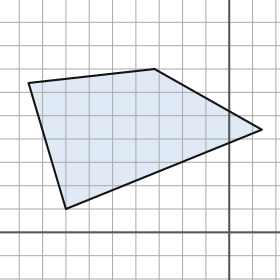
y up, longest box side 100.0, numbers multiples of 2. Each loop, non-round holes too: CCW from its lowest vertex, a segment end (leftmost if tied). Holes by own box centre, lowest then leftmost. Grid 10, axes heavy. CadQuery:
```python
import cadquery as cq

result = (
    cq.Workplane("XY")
    .moveTo(-70.0, 10.0)
    .lineTo(14.0, 44.0)
    .lineTo(-32.0, 70.0)
    .lineTo(-86.0, 64.0)
    .close()
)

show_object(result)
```